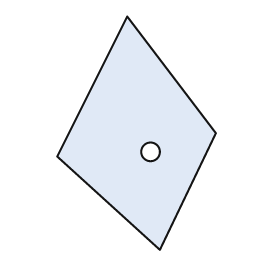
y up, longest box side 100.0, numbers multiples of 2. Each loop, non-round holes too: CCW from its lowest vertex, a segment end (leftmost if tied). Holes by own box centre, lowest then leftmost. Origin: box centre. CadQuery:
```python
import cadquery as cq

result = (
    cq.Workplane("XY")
    .moveTo(10.0, -50.0)
    .lineTo(34.0, 0.0)
    .lineTo(-4.0, 50.0)
    .lineTo(-34.0, -10.0)
    .close()
    .moveTo(6.0, -8.0)
    .circle(4.0)
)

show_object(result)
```